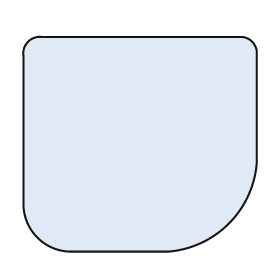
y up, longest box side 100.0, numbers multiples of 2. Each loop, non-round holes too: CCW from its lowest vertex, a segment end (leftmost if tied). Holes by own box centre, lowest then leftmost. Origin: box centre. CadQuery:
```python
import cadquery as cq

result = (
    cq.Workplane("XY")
    .moveTo(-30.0, -46.0)
    .lineTo(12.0, -46.0)
    .threePointArc((38.0, -34.0), (50.0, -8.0))
    .lineTo(50.0, 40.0)
    .threePointArc((48.0, 44.0), (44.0, 46.0))
    .lineTo(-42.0, 46.0)
    .threePointArc((-48.0, 44.0), (-50.0, 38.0))
    .lineTo(-50.0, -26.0)
    .threePointArc((-44.0, -40.0), (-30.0, -46.0))
    .close()
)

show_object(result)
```